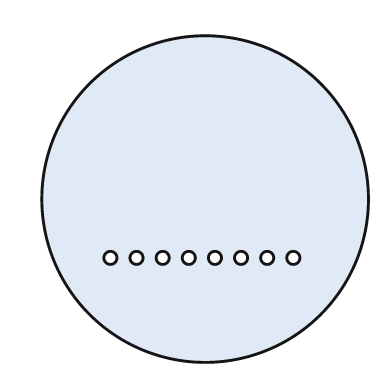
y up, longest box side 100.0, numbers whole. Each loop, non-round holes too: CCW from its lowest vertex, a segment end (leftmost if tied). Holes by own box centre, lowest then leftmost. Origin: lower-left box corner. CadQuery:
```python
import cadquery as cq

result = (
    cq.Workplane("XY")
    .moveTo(50.0, 50.0)
    .circle(50.0)
    .moveTo(21.0, 32.0)
    .circle(2.0)
    .moveTo(29.0, 32.0)
    .circle(2.0)
    .moveTo(37.0, 32.0)
    .circle(2.0)
    .moveTo(45.0, 32.0)
    .circle(2.0)
    .moveTo(53.0, 32.0)
    .circle(2.0)
    .moveTo(61.0, 32.0)
    .circle(2.0)
    .moveTo(69.0, 32.0)
    .circle(2.0)
    .moveTo(77.0, 32.0)
    .circle(2.0)
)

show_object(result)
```